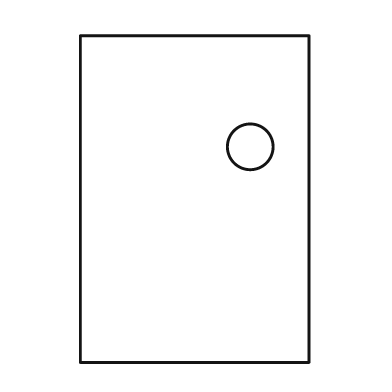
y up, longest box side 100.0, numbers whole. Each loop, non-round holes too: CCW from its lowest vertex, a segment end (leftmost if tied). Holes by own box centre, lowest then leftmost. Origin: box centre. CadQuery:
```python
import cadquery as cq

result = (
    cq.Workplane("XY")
    .moveTo(-35.0, -50.0)
    .lineTo(35.0, -50.0)
    .lineTo(35.0, 50.0)
    .lineTo(-35.0, 50.0)
    .close()
    .moveTo(17.0, 16.0)
    .circle(7.0)
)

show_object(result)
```